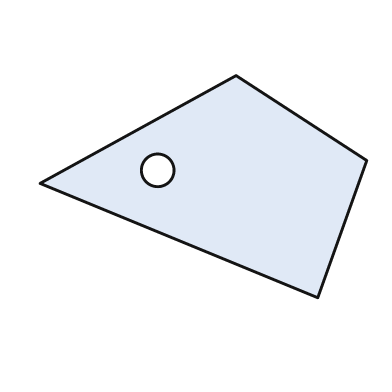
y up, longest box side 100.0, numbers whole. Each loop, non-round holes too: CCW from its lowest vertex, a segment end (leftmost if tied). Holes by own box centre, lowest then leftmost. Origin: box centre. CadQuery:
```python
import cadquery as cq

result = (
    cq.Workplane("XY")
    .moveTo(35.0, -34.0)
    .lineTo(50.0, 8.0)
    .lineTo(10.0, 34.0)
    .lineTo(-50.0, 1.0)
    .close()
    .moveTo(-14.0, 5.0)
    .circle(5.0)
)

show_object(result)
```